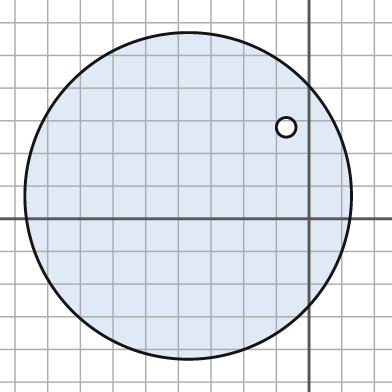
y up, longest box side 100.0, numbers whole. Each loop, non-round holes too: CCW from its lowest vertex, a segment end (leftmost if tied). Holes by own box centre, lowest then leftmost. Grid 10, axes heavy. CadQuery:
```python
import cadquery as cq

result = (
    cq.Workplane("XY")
    .moveTo(-37.0, 7.0)
    .circle(50.0)
    .moveTo(-7.0, 28.0)
    .circle(3.0)
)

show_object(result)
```